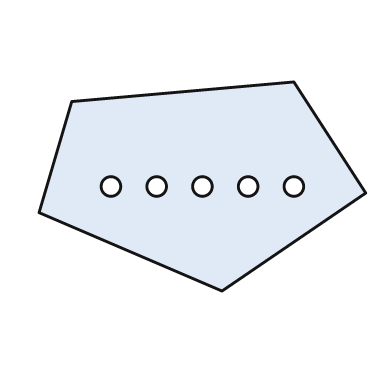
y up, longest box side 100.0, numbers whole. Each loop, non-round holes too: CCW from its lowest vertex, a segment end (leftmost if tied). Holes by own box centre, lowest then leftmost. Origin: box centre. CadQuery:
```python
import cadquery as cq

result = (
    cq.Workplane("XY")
    .moveTo(6.0, -32.0)
    .lineTo(50.0, -2.0)
    .lineTo(28.0, 32.0)
    .lineTo(-40.0, 26.0)
    .lineTo(-50.0, -8.0)
    .close()
    .moveTo(-28.0, 0.0)
    .circle(3.0)
    .moveTo(-14.0, 0.0)
    .circle(3.0)
    .moveTo(0.0, 0.0)
    .circle(3.0)
    .moveTo(14.0, 0.0)
    .circle(3.0)
    .moveTo(28.0, 0.0)
    .circle(3.0)
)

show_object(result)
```